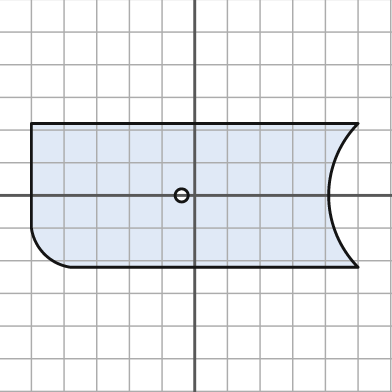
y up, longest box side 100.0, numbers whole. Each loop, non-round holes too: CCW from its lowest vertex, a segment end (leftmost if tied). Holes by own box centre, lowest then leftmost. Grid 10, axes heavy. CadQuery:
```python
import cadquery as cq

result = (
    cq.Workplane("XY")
    .moveTo(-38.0, -22.0)
    .lineTo(50.0, -22.0)
    .threePointArc((41.0, 0.0), (50.0, 22.0))
    .lineTo(-50.0, 22.0)
    .lineTo(-50.0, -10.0)
    .threePointArc((-46.0, -18.0), (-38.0, -22.0))
    .close()
    .moveTo(-4.0, 0.0)
    .circle(2.0)
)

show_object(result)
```